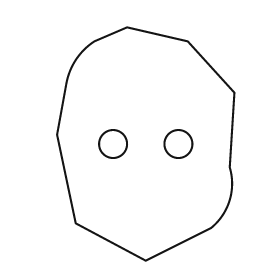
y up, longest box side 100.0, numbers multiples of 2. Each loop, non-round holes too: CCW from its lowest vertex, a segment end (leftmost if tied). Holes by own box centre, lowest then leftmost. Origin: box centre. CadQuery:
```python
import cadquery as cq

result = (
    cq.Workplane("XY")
    .moveTo(0.0, -50.0)
    .lineTo(28.0, -36.0)
    .threePointArc((36.0, -24.0), (36.0, -10.0))
    .lineTo(38.0, 22.0)
    .lineTo(18.0, 44.0)
    .lineTo(-8.0, 50.0)
    .lineTo(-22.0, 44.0)
    .threePointArc((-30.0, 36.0), (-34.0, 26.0))
    .lineTo(-38.0, 4.0)
    .lineTo(-30.0, -34.0)
    .close()
    .moveTo(-14.0, 0.0)
    .circle(6.0)
    .moveTo(14.0, 0.0)
    .circle(6.0)
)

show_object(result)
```